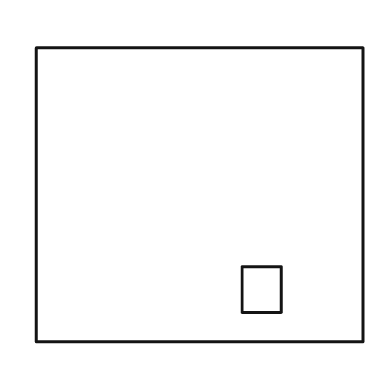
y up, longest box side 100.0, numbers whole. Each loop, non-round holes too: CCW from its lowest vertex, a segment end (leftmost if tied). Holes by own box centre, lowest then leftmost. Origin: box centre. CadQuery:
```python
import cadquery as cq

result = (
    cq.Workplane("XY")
    .moveTo(-50.0, -45.0)
    .lineTo(50.0, -45.0)
    .lineTo(50.0, 45.0)
    .lineTo(-50.0, 45.0)
    .close()
    .moveTo(13.0, -36.0)
    .lineTo(25.0, -36.0)
    .lineTo(25.0, -22.0)
    .lineTo(13.0, -22.0)
    .close()
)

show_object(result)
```